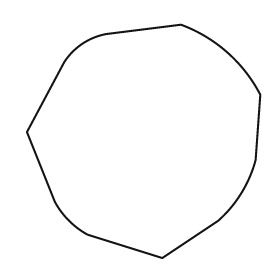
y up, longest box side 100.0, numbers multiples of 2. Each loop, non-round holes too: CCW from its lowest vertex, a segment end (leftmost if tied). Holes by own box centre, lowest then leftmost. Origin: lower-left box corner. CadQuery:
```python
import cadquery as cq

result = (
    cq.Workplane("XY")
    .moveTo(58.0, 0.0)
    .lineTo(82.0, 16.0)
    .threePointArc((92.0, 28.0), (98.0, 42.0))
    .lineTo(100.0, 70.0)
    .threePointArc((86.0, 88.0), (66.0, 100.0))
    .lineTo(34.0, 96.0)
    .threePointArc((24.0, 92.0), (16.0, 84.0))
    .lineTo(0.0, 54.0)
    .lineTo(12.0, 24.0)
    .threePointArc((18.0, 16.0), (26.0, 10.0))
    .close()
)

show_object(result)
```